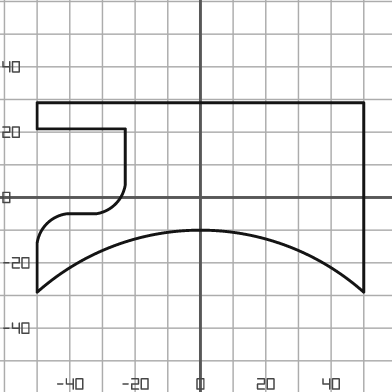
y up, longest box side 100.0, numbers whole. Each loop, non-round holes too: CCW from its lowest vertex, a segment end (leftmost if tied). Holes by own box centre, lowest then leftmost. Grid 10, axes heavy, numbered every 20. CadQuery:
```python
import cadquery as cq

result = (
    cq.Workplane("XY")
    .moveTo(-50.0, -29.0)
    .threePointArc((0.0, -10.0), (50.0, -29.0))
    .lineTo(50.0, 29.0)
    .lineTo(-50.0, 29.0)
    .lineTo(-50.0, 21.0)
    .lineTo(-23.0, 21.0)
    .lineTo(-23.0, 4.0)
    .threePointArc((-26.0, -2.0), (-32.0, -5.0))
    .lineTo(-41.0, -5.0)
    .threePointArc((-47.0, -8.0), (-50.0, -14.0))
    .close()
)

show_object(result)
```